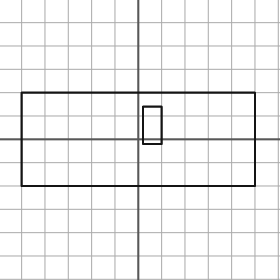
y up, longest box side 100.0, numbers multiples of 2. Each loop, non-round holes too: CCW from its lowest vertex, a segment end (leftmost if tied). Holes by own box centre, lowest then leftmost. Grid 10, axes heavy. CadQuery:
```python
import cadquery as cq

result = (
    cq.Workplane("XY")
    .moveTo(-50.0, -20.0)
    .lineTo(50.0, -20.0)
    .lineTo(50.0, 20.0)
    .lineTo(-50.0, 20.0)
    .close()
    .moveTo(2.0, -2.0)
    .lineTo(10.0, -2.0)
    .lineTo(10.0, 14.0)
    .lineTo(2.0, 14.0)
    .close()
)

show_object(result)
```